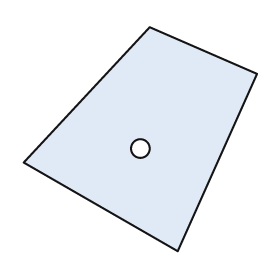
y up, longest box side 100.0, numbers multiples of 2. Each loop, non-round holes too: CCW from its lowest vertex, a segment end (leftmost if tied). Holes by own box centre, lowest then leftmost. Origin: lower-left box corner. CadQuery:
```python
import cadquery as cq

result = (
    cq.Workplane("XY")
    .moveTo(66.0, 0.0)
    .lineTo(100.0, 76.0)
    .lineTo(54.0, 96.0)
    .lineTo(0.0, 38.0)
    .close()
    .moveTo(50.0, 44.0)
    .circle(4.0)
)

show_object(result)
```